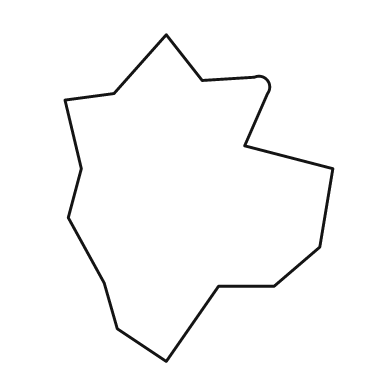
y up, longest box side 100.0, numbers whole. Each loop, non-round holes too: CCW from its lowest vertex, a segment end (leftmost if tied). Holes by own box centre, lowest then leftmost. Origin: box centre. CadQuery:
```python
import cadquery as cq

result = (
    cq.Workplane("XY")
    .moveTo(-10.0, -50.0)
    .lineTo(6.0, -27.0)
    .lineTo(23.0, -27.0)
    .lineTo(37.0, -15.0)
    .lineTo(41.0, 9.0)
    .lineTo(14.0, 16.0)
    .lineTo(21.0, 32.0)
    .threePointArc((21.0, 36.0), (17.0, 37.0))
    .lineTo(1.0, 36.0)
    .lineTo(-10.0, 50.0)
    .lineTo(-26.0, 32.0)
    .lineTo(-41.0, 30.0)
    .lineTo(-36.0, 9.0)
    .lineTo(-40.0, -6.0)
    .lineTo(-29.0, -26.0)
    .lineTo(-25.0, -40.0)
    .close()
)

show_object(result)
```